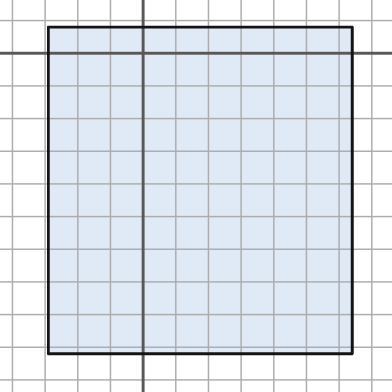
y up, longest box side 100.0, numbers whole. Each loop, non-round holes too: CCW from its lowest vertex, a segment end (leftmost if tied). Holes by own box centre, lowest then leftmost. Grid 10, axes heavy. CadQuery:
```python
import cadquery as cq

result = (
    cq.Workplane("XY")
    .moveTo(-29.0, -92.0)
    .lineTo(64.0, -92.0)
    .lineTo(64.0, 8.0)
    .lineTo(-29.0, 8.0)
    .close()
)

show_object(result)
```